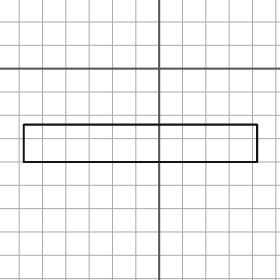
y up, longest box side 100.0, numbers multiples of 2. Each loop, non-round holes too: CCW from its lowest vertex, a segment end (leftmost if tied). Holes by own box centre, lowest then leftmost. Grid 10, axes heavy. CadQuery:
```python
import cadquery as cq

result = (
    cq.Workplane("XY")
    .moveTo(-58.0, -40.0)
    .lineTo(42.0, -40.0)
    .lineTo(42.0, -24.0)
    .lineTo(-58.0, -24.0)
    .close()
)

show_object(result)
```